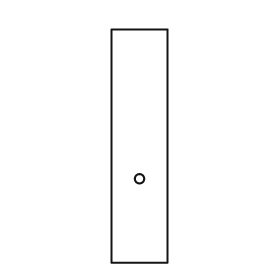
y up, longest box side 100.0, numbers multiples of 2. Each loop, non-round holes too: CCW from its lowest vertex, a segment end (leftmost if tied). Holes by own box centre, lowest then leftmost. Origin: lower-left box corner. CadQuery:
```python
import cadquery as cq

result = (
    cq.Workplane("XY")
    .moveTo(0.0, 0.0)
    .lineTo(24.0, 0.0)
    .lineTo(24.0, 100.0)
    .lineTo(0.0, 100.0)
    .close()
    .moveTo(12.0, 36.0)
    .circle(2.0)
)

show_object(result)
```